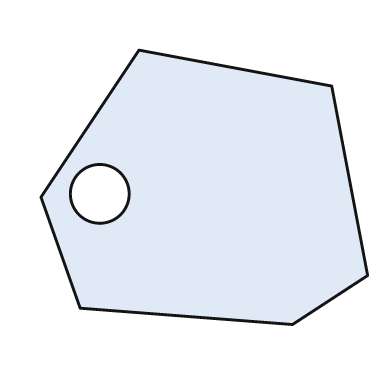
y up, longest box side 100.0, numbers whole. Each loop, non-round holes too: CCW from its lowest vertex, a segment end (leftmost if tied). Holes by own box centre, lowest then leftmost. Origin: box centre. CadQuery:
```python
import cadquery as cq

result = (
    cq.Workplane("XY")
    .moveTo(27.0, -42.0)
    .lineTo(50.0, -27.0)
    .lineTo(39.0, 31.0)
    .lineTo(-20.0, 42.0)
    .lineTo(-50.0, -3.0)
    .lineTo(-38.0, -37.0)
    .close()
    .moveTo(-32.0, -2.0)
    .circle(9.0)
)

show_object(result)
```